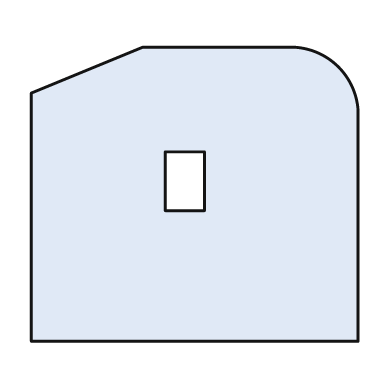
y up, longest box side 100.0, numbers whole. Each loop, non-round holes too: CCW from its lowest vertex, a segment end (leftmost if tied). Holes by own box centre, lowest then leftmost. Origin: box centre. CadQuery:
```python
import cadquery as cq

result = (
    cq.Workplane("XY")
    .moveTo(-50.0, -45.0)
    .lineTo(50.0, -45.0)
    .lineTo(50.0, 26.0)
    .threePointArc((44.0, 39.0), (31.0, 45.0))
    .lineTo(-16.0, 45.0)
    .lineTo(-50.0, 31.0)
    .close()
    .moveTo(-9.0, -5.0)
    .lineTo(3.0, -5.0)
    .lineTo(3.0, 13.0)
    .lineTo(-9.0, 13.0)
    .close()
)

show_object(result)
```